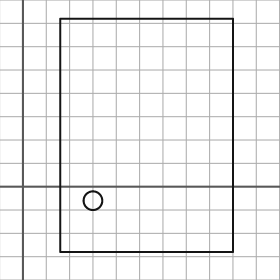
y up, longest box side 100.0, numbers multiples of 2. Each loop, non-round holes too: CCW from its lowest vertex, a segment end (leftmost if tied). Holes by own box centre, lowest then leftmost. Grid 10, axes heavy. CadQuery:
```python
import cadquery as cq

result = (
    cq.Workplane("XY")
    .moveTo(16.0, -28.0)
    .lineTo(90.0, -28.0)
    .lineTo(90.0, 72.0)
    .lineTo(16.0, 72.0)
    .close()
    .moveTo(30.0, -6.0)
    .circle(4.0)
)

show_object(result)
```